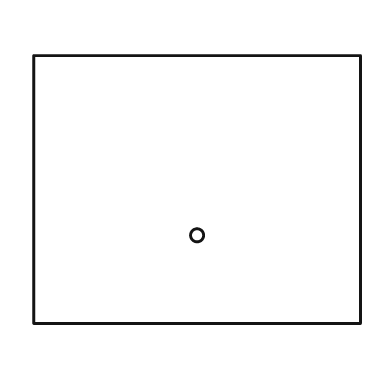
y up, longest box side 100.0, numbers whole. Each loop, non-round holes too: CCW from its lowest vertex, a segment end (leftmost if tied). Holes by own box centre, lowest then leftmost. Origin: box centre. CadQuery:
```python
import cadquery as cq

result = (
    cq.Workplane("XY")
    .moveTo(-50.0, -41.0)
    .lineTo(50.0, -41.0)
    .lineTo(50.0, 41.0)
    .lineTo(-50.0, 41.0)
    .close()
    .moveTo(0.0, -14.0)
    .circle(2.0)
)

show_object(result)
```